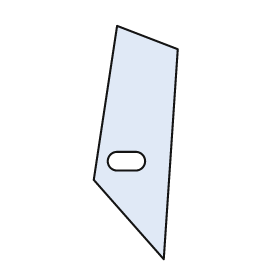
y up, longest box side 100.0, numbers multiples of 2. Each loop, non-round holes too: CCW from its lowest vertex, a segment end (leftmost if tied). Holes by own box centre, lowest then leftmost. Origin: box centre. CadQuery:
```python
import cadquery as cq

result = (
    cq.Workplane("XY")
    .moveTo(12.0, -50.0)
    .lineTo(18.0, 40.0)
    .lineTo(-8.0, 50.0)
    .lineTo(-18.0, -16.0)
    .close()
    .moveTo(-8.0, -12.0)
    .lineTo(0.0, -12.0)
    .threePointArc((4.0, -8.0), (0.0, -4.0))
    .lineTo(-8.0, -4.0)
    .threePointArc((-12.0, -8.0), (-8.0, -12.0))
    .close()
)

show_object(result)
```